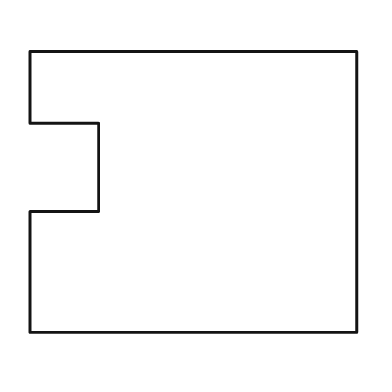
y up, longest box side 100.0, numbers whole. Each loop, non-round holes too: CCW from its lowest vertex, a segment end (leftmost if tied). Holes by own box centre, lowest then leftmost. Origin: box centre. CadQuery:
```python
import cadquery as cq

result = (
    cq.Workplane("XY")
    .moveTo(-50.0, -43.0)
    .lineTo(50.0, -43.0)
    .lineTo(50.0, 43.0)
    .lineTo(-50.0, 43.0)
    .lineTo(-50.0, 21.0)
    .lineTo(-29.0, 21.0)
    .lineTo(-29.0, -6.0)
    .lineTo(-50.0, -6.0)
    .close()
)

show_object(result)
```